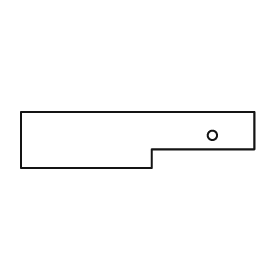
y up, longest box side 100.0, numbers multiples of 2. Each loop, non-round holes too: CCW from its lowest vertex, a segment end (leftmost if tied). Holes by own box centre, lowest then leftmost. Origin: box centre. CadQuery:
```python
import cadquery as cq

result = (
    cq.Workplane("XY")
    .moveTo(-50.0, -12.0)
    .lineTo(6.0, -12.0)
    .lineTo(6.0, -4.0)
    .lineTo(50.0, -4.0)
    .lineTo(50.0, 12.0)
    .lineTo(-50.0, 12.0)
    .close()
    .moveTo(32.0, 2.0)
    .circle(2.0)
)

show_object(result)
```